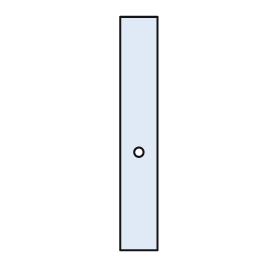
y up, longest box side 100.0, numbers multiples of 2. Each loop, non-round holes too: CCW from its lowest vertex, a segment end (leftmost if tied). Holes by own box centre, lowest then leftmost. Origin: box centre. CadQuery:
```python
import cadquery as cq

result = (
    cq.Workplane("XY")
    .moveTo(-8.0, -50.0)
    .lineTo(8.0, -50.0)
    .lineTo(8.0, 50.0)
    .lineTo(-8.0, 50.0)
    .close()
    .moveTo(0.0, -8.0)
    .circle(2.0)
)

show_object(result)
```